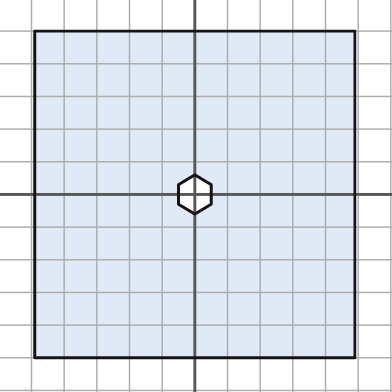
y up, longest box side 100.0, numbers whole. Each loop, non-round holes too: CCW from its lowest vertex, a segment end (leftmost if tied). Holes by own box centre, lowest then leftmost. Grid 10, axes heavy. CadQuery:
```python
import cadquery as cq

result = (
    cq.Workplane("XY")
    .moveTo(-49.0, -50.0)
    .lineTo(49.0, -50.0)
    .lineTo(49.0, 50.0)
    .lineTo(-49.0, 50.0)
    .close()
    .moveTo(0.0, -6.0)
    .lineTo(5.0, -3.0)
    .lineTo(5.0, 3.0)
    .lineTo(0.0, 6.0)
    .lineTo(-5.0, 3.0)
    .lineTo(-5.0, -3.0)
    .close()
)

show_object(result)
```